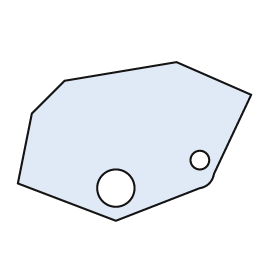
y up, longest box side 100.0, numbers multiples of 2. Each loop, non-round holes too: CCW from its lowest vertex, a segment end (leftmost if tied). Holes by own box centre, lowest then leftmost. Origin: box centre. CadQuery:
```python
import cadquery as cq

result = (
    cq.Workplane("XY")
    .moveTo(-8.0, -34.0)
    .lineTo(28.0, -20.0)
    .threePointArc((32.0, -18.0), (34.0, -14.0))
    .lineTo(50.0, 20.0)
    .lineTo(18.0, 34.0)
    .lineTo(-30.0, 26.0)
    .lineTo(-44.0, 12.0)
    .lineTo(-50.0, -18.0)
    .close()
    .moveTo(-8.0, -20.0)
    .circle(8.0)
    .moveTo(28.0, -8.0)
    .circle(4.0)
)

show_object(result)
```